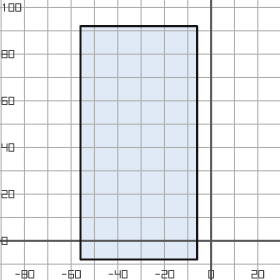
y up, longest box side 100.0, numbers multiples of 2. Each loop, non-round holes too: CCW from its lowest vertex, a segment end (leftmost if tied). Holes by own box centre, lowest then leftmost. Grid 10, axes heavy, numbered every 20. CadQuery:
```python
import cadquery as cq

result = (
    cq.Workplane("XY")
    .moveTo(-56.0, -8.0)
    .lineTo(-6.0, -8.0)
    .lineTo(-6.0, 92.0)
    .lineTo(-56.0, 92.0)
    .close()
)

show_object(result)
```